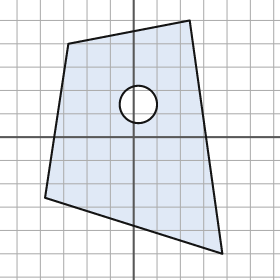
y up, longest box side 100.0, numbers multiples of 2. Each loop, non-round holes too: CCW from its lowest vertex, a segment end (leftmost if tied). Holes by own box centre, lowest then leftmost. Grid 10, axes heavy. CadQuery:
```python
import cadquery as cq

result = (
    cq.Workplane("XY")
    .moveTo(38.0, -50.0)
    .lineTo(24.0, 50.0)
    .lineTo(-28.0, 40.0)
    .lineTo(-38.0, -26.0)
    .close()
    .moveTo(2.0, 14.0)
    .circle(8.0)
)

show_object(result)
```